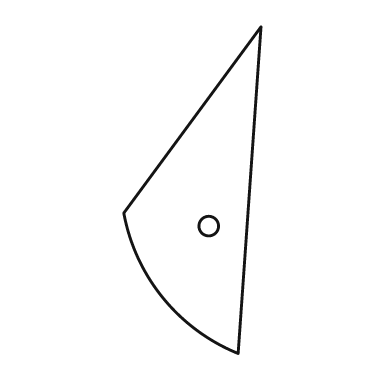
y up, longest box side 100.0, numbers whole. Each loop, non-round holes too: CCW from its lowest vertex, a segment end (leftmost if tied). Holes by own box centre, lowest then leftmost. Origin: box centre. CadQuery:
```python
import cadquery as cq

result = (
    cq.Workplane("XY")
    .moveTo(14.0, -50.0)
    .lineTo(21.0, 50.0)
    .lineTo(-21.0, -7.0)
    .threePointArc((-9.0, -33.0), (14.0, -50.0))
    .close()
    .moveTo(5.0, -11.0)
    .circle(3.0)
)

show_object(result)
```